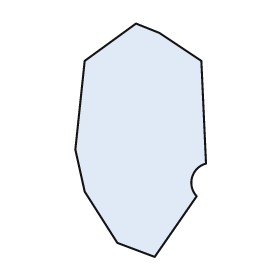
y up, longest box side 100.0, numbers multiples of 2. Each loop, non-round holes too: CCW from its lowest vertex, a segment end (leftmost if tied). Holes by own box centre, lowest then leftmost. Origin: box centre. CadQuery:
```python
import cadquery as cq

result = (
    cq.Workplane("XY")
    .moveTo(6.0, -50.0)
    .lineTo(24.0, -24.0)
    .threePointArc((22.0, -16.0), (28.0, -10.0))
    .lineTo(26.0, 34.0)
    .lineTo(8.0, 46.0)
    .lineTo(-2.0, 50.0)
    .lineTo(-24.0, 34.0)
    .lineTo(-28.0, -4.0)
    .lineTo(-24.0, -22.0)
    .lineTo(-10.0, -44.0)
    .close()
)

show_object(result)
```